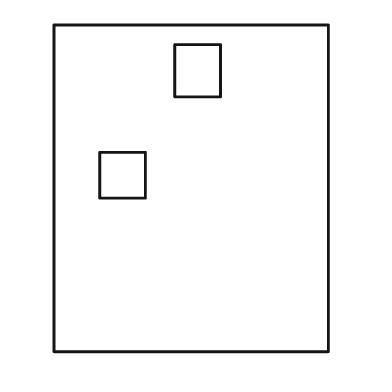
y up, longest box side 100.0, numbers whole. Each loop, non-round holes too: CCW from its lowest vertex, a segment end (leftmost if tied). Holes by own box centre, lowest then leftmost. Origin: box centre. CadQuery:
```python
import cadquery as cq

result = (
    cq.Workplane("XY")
    .moveTo(-42.0, -50.0)
    .lineTo(42.0, -50.0)
    .lineTo(42.0, 50.0)
    .lineTo(-42.0, 50.0)
    .close()
    .moveTo(-28.0, -3.0)
    .lineTo(-14.0, -3.0)
    .lineTo(-14.0, 11.0)
    .lineTo(-28.0, 11.0)
    .close()
    .moveTo(-5.0, 28.0)
    .lineTo(9.0, 28.0)
    .lineTo(9.0, 44.0)
    .lineTo(-5.0, 44.0)
    .close()
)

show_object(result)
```